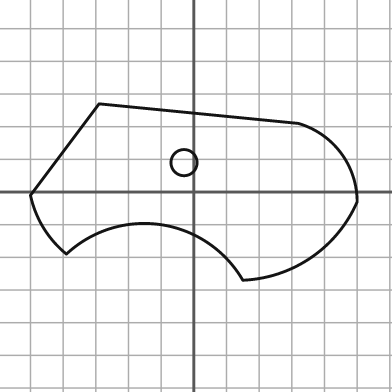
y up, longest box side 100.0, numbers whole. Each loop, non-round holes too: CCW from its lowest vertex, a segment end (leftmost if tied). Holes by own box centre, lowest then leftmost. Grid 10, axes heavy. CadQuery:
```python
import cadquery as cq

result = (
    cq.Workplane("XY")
    .moveTo(15.0, -27.0)
    .threePointArc((36.0, -20.0), (50.0, -3.0))
    .threePointArc((45.0, 12.0), (32.0, 21.0))
    .lineTo(-29.0, 27.0)
    .lineTo(-50.0, -1.0)
    .threePointArc((-46.0, -11.0), (-39.0, -19.0))
    .threePointArc((-10.0, -10.0), (15.0, -27.0))
    .close()
    .moveTo(-3.0, 9.0)
    .circle(4.0)
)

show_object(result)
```